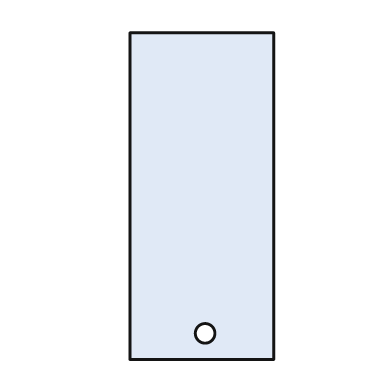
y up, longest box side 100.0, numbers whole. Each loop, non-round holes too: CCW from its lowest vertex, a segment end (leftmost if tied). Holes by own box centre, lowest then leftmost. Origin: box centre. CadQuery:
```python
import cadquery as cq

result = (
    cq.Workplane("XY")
    .moveTo(-22.0, -50.0)
    .lineTo(22.0, -50.0)
    .lineTo(22.0, 50.0)
    .lineTo(-22.0, 50.0)
    .close()
    .moveTo(1.0, -42.0)
    .circle(3.0)
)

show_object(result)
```